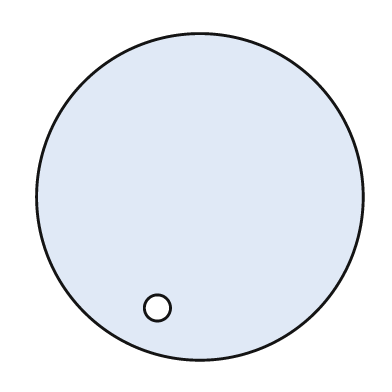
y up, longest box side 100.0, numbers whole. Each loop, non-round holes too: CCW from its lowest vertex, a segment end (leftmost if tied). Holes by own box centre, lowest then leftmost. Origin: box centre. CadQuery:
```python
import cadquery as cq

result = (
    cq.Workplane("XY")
    .moveTo(0.0, 0.0)
    .circle(50.0)
    .moveTo(-13.0, -34.0)
    .circle(4.0)
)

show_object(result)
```